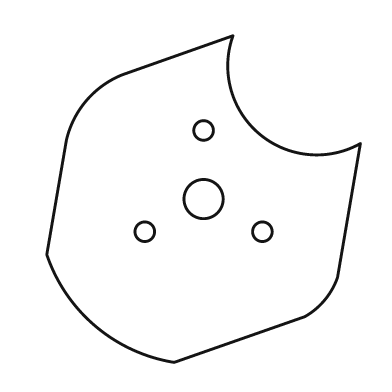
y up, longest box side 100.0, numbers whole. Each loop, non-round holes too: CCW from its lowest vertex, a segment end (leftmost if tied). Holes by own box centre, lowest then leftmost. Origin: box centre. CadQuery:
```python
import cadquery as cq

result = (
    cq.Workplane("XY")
    .moveTo(-9.0, -50.0)
    .lineTo(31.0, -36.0)
    .threePointArc((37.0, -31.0), (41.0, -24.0))
    .lineTo(48.0, 17.0)
    .threePointArc((17.0, 20.0), (9.0, 50.0))
    .lineTo(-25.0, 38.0)
    .threePointArc((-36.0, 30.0), (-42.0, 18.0))
    .lineTo(-48.0, -17.0)
    .threePointArc((-33.0, -39.0), (-9.0, -50.0))
    .close()
    .moveTo(-18.0, -10.0)
    .circle(3.0)
    .moveTo(18.0, -10.0)
    .circle(3.0)
    .moveTo(0.0, 0.0)
    .circle(6.0)
    .moveTo(0.0, 21.0)
    .circle(3.0)
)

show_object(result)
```